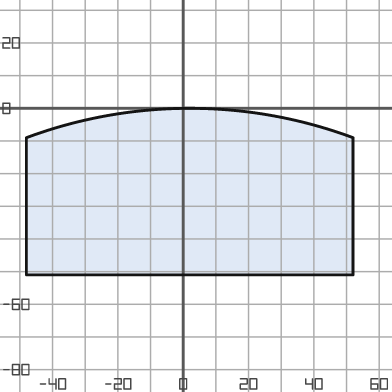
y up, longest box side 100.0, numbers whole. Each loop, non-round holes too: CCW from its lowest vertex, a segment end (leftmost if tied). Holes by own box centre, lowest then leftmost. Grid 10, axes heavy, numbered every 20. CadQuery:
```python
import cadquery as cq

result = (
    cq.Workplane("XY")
    .moveTo(-48.0, -51.0)
    .lineTo(52.0, -51.0)
    .lineTo(52.0, -9.0)
    .threePointArc((2.0, 0.0), (-48.0, -9.0))
    .close()
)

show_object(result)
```